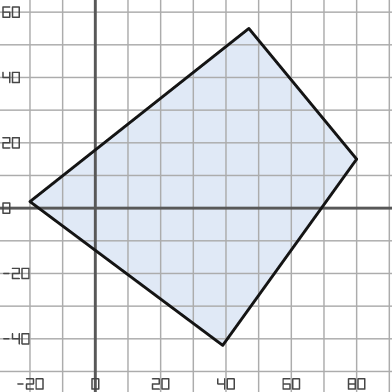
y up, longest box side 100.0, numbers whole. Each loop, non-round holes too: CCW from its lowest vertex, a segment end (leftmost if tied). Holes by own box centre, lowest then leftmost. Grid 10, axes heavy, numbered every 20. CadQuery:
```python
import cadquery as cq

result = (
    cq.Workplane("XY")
    .moveTo(39.0, -42.0)
    .lineTo(80.0, 15.0)
    .lineTo(47.0, 55.0)
    .lineTo(-20.0, 2.0)
    .close()
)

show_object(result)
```